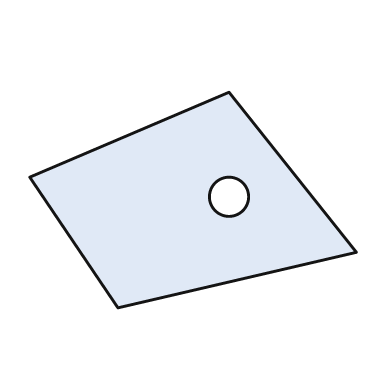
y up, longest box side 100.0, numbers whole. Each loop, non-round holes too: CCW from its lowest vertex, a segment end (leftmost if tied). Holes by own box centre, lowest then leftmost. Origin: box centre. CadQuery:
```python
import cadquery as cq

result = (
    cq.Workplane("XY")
    .moveTo(-23.0, -33.0)
    .lineTo(50.0, -16.0)
    .lineTo(11.0, 33.0)
    .lineTo(-50.0, 7.0)
    .close()
    .moveTo(11.0, 1.0)
    .circle(6.0)
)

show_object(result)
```